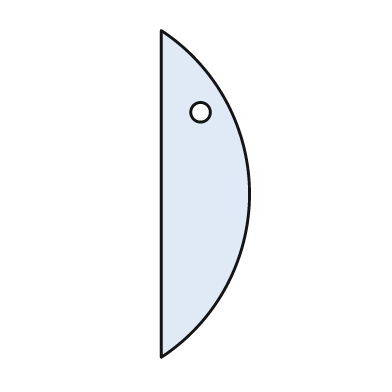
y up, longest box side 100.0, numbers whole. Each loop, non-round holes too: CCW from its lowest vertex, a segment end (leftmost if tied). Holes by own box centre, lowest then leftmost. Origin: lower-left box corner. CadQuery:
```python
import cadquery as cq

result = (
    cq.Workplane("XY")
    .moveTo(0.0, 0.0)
    .threePointArc((27.0, 50.0), (0.0, 100.0))
    .close()
    .moveTo(12.0, 75.0)
    .circle(3.0)
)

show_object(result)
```